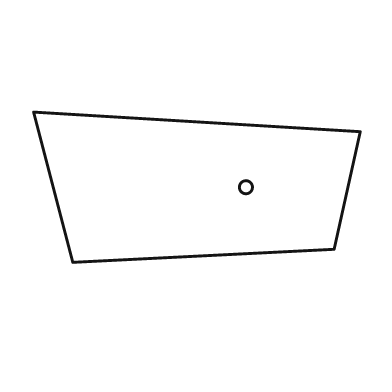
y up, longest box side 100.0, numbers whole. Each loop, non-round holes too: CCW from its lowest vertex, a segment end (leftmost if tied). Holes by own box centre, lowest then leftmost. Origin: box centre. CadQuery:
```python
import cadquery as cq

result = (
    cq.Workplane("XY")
    .moveTo(-38.0, -23.0)
    .lineTo(42.0, -19.0)
    .lineTo(50.0, 17.0)
    .lineTo(-50.0, 23.0)
    .close()
    .moveTo(15.0, 0.0)
    .circle(2.0)
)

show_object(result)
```